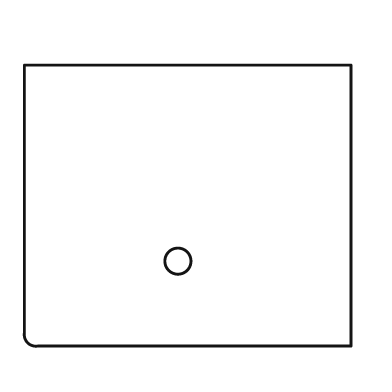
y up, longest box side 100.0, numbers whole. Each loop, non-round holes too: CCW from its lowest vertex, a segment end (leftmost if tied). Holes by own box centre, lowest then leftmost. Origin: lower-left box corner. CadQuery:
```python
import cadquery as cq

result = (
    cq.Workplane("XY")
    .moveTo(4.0, 0.0)
    .lineTo(100.0, 0.0)
    .lineTo(100.0, 86.0)
    .lineTo(0.0, 86.0)
    .lineTo(0.0, 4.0)
    .threePointArc((1.0, 1.0), (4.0, 0.0))
    .close()
    .moveTo(47.0, 26.0)
    .circle(4.0)
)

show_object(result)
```